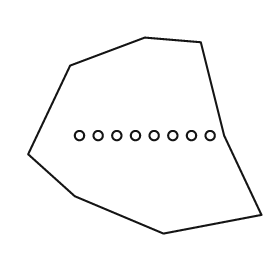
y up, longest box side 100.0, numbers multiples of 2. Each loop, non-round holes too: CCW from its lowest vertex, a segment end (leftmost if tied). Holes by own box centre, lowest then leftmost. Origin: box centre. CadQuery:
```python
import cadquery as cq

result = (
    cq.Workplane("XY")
    .moveTo(8.0, -42.0)
    .lineTo(50.0, -34.0)
    .lineTo(34.0, 0.0)
    .lineTo(24.0, 40.0)
    .lineTo(0.0, 42.0)
    .lineTo(-32.0, 30.0)
    .lineTo(-50.0, -8.0)
    .lineTo(-30.0, -26.0)
    .close()
    .moveTo(-28.0, 0.0)
    .circle(2.0)
    .moveTo(-20.0, 0.0)
    .circle(2.0)
    .moveTo(-12.0, 0.0)
    .circle(2.0)
    .moveTo(-4.0, 0.0)
    .circle(2.0)
    .moveTo(4.0, 0.0)
    .circle(2.0)
    .moveTo(12.0, 0.0)
    .circle(2.0)
    .moveTo(20.0, 0.0)
    .circle(2.0)
    .moveTo(28.0, 0.0)
    .circle(2.0)
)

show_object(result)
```